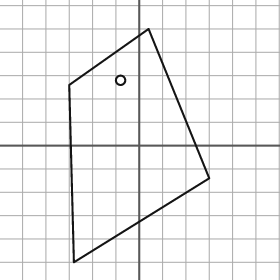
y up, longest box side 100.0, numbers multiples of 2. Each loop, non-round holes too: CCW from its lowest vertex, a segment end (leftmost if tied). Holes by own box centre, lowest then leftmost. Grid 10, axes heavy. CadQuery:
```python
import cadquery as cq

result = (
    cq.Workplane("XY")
    .moveTo(-28.0, -50.0)
    .lineTo(30.0, -14.0)
    .lineTo(4.0, 50.0)
    .lineTo(-30.0, 26.0)
    .close()
    .moveTo(-8.0, 28.0)
    .circle(2.0)
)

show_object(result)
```